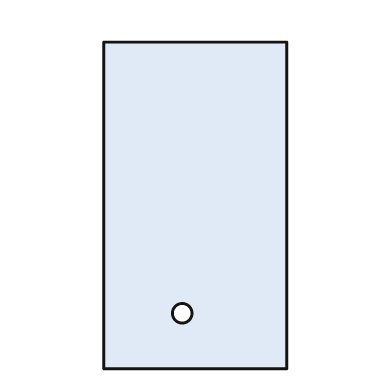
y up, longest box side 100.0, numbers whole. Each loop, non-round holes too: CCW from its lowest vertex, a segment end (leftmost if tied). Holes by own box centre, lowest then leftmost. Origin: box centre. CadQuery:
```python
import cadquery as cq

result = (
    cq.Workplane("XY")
    .moveTo(-28.0, -50.0)
    .lineTo(28.0, -50.0)
    .lineTo(28.0, 50.0)
    .lineTo(-28.0, 50.0)
    .close()
    .moveTo(-4.0, -33.0)
    .circle(3.0)
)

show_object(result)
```